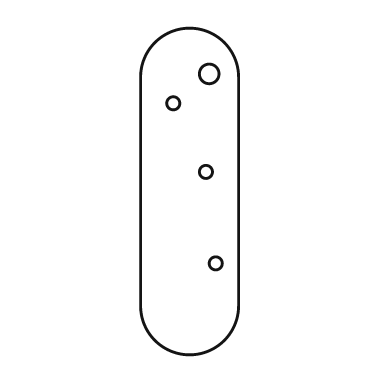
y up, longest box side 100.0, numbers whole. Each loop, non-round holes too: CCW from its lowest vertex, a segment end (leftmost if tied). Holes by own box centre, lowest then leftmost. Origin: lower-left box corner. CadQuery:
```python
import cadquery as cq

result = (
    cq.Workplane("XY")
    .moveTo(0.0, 15.0)
    .threePointArc((15.0, 0.0), (30.0, 15.0))
    .lineTo(30.0, 85.0)
    .threePointArc((15.0, 100.0), (0.0, 85.0))
    .close()
    .moveTo(23.0, 28.0)
    .circle(2.0)
    .moveTo(20.0, 56.0)
    .circle(2.0)
    .moveTo(10.0, 77.0)
    .circle(2.0)
    .moveTo(21.0, 86.0)
    .circle(3.0)
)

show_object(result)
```